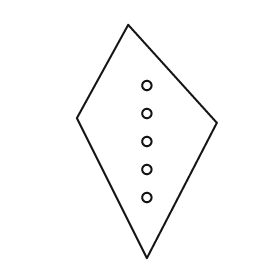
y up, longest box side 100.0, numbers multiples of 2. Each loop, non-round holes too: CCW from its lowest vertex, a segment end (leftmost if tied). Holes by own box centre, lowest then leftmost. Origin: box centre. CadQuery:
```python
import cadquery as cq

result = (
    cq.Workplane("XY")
    .moveTo(0.0, -50.0)
    .lineTo(30.0, 8.0)
    .lineTo(-8.0, 50.0)
    .lineTo(-30.0, 10.0)
    .close()
    .moveTo(0.0, -24.0)
    .circle(2.0)
    .moveTo(0.0, -12.0)
    .circle(2.0)
    .moveTo(0.0, 0.0)
    .circle(2.0)
    .moveTo(0.0, 12.0)
    .circle(2.0)
    .moveTo(0.0, 24.0)
    .circle(2.0)
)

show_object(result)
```